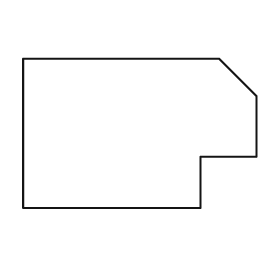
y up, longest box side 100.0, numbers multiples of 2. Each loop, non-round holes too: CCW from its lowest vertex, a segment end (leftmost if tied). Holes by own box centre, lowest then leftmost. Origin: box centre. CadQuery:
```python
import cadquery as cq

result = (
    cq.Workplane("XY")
    .moveTo(-50.0, -32.0)
    .lineTo(26.0, -32.0)
    .lineTo(26.0, -10.0)
    .lineTo(50.0, -10.0)
    .lineTo(50.0, 16.0)
    .lineTo(34.0, 32.0)
    .lineTo(-50.0, 32.0)
    .close()
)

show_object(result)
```